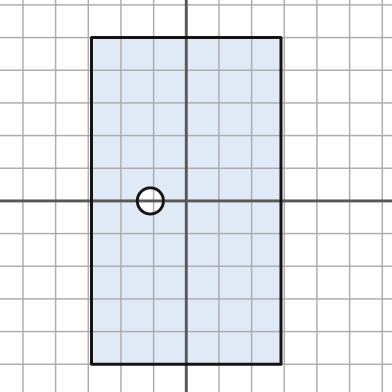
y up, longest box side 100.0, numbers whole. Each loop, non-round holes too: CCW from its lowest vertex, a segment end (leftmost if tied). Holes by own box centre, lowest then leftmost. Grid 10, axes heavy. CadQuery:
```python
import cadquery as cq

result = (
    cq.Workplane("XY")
    .moveTo(-29.0, -50.0)
    .lineTo(29.0, -50.0)
    .lineTo(29.0, 50.0)
    .lineTo(-29.0, 50.0)
    .close()
    .moveTo(-11.0, 0.0)
    .circle(4.0)
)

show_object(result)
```